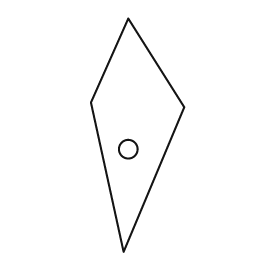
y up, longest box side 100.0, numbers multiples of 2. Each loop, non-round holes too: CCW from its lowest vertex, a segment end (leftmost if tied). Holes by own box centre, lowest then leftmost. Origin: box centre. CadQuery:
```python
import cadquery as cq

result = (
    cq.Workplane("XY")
    .moveTo(-6.0, -50.0)
    .lineTo(20.0, 12.0)
    .lineTo(-4.0, 50.0)
    .lineTo(-20.0, 14.0)
    .close()
    .moveTo(-4.0, -6.0)
    .circle(4.0)
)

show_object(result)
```